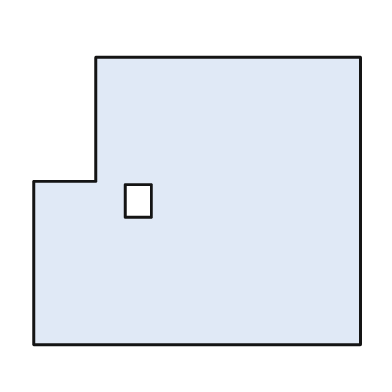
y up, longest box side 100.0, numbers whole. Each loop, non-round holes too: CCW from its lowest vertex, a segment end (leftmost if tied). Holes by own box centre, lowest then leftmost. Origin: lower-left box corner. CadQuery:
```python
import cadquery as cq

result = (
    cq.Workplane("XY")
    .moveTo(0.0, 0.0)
    .lineTo(100.0, 0.0)
    .lineTo(100.0, 88.0)
    .lineTo(19.0, 88.0)
    .lineTo(19.0, 50.0)
    .lineTo(0.0, 50.0)
    .close()
    .moveTo(28.0, 39.0)
    .lineTo(36.0, 39.0)
    .lineTo(36.0, 49.0)
    .lineTo(28.0, 49.0)
    .close()
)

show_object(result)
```